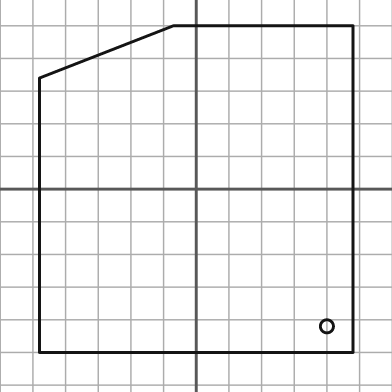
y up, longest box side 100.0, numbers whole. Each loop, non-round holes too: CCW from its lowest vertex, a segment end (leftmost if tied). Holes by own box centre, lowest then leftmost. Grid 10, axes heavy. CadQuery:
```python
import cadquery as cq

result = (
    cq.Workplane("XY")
    .moveTo(-48.0, -50.0)
    .lineTo(48.0, -50.0)
    .lineTo(48.0, 50.0)
    .lineTo(-7.0, 50.0)
    .lineTo(-48.0, 34.0)
    .close()
    .moveTo(40.0, -42.0)
    .circle(2.0)
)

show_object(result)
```